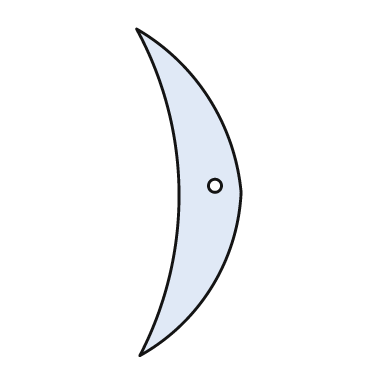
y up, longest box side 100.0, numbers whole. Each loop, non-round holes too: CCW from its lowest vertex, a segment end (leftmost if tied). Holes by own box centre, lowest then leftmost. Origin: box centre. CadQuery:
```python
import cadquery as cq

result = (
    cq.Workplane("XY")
    .moveTo(-15.0, -50.0)
    .threePointArc((7.0, -29.0), (16.0, 0.0))
    .threePointArc((6.0, 29.0), (-16.0, 50.0))
    .threePointArc((-3.0, 0.0), (-15.0, -50.0))
    .close()
    .moveTo(8.0, 2.0)
    .circle(2.0)
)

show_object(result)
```